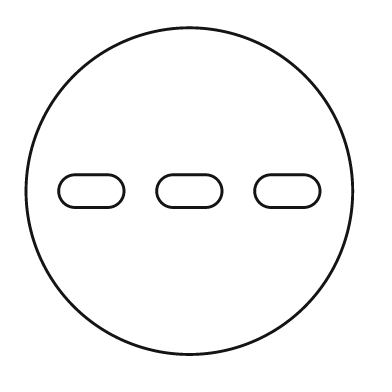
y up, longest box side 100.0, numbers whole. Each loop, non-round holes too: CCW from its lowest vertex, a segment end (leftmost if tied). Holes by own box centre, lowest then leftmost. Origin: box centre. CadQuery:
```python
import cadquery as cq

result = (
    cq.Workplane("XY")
    .moveTo(0.0, 0.0)
    .circle(50.0)
    .moveTo(-35.0, -5.0)
    .lineTo(-25.0, -5.0)
    .threePointArc((-20.0, 0.0), (-25.0, 5.0))
    .lineTo(-35.0, 5.0)
    .threePointArc((-40.0, 0.0), (-35.0, -5.0))
    .close()
    .moveTo(-5.0, -5.0)
    .lineTo(5.0, -5.0)
    .threePointArc((10.0, 0.0), (5.0, 5.0))
    .lineTo(-5.0, 5.0)
    .threePointArc((-10.0, 0.0), (-5.0, -5.0))
    .close()
    .moveTo(25.0, -5.0)
    .lineTo(35.0, -5.0)
    .threePointArc((40.0, 0.0), (35.0, 5.0))
    .lineTo(25.0, 5.0)
    .threePointArc((20.0, 0.0), (25.0, -5.0))
    .close()
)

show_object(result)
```